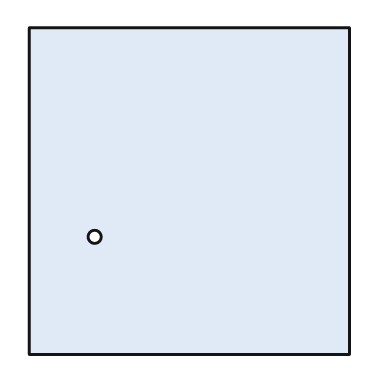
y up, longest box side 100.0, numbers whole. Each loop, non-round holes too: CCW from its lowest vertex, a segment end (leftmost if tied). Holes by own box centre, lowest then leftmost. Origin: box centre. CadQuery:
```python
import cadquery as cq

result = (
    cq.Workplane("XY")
    .moveTo(-49.0, -50.0)
    .lineTo(49.0, -50.0)
    .lineTo(49.0, 50.0)
    .lineTo(-49.0, 50.0)
    .close()
    .moveTo(-29.0, -14.0)
    .circle(2.0)
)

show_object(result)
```